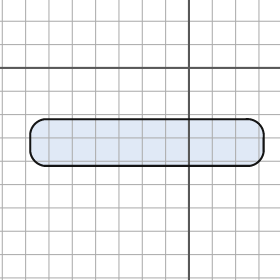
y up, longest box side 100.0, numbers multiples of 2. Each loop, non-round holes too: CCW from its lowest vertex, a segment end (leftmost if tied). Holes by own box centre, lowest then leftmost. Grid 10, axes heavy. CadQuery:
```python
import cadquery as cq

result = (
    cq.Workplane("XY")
    .moveTo(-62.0, -42.0)
    .lineTo(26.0, -42.0)
    .threePointArc((30.0, -40.0), (32.0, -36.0))
    .lineTo(32.0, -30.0)
    .threePointArc((30.0, -24.0), (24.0, -22.0))
    .lineTo(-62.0, -22.0)
    .threePointArc((-66.0, -24.0), (-68.0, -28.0))
    .lineTo(-68.0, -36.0)
    .threePointArc((-66.0, -40.0), (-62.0, -42.0))
    .close()
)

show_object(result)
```